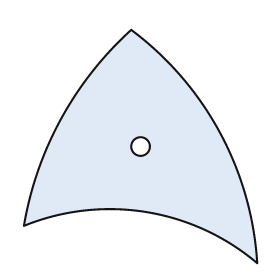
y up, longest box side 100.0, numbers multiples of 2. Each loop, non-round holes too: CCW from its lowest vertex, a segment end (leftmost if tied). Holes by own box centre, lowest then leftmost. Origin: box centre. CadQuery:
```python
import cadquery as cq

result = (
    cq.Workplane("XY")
    .moveTo(50.0, -50.0)
    .threePointArc((34.0, 6.0), (-4.0, 50.0))
    .threePointArc((-34.0, 12.0), (-50.0, -34.0))
    .threePointArc((2.0, -28.0), (50.0, -50.0))
    .close()
    .moveTo(0.0, 0.0)
    .circle(4.0)
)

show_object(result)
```